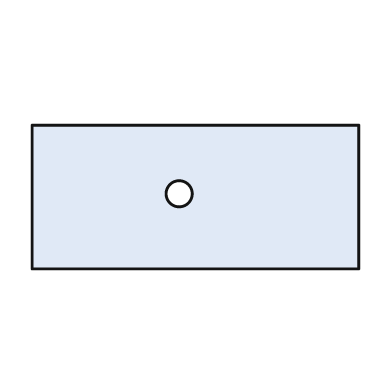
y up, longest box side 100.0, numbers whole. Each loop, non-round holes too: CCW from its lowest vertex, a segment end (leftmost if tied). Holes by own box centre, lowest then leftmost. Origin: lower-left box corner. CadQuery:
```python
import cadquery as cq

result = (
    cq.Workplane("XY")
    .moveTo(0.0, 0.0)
    .lineTo(100.0, 0.0)
    .lineTo(100.0, 44.0)
    .lineTo(0.0, 44.0)
    .close()
    .moveTo(45.0, 23.0)
    .circle(4.0)
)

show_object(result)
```